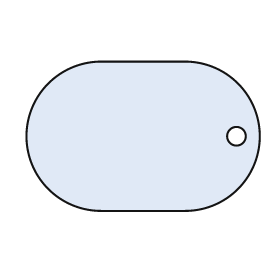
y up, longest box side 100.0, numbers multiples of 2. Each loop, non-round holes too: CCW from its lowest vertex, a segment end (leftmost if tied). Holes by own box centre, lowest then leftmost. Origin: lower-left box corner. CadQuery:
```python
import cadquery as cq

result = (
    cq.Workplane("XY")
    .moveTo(32.0, 0.0)
    .lineTo(68.0, 0.0)
    .threePointArc((100.0, 32.0), (68.0, 64.0))
    .lineTo(32.0, 64.0)
    .threePointArc((0.0, 32.0), (32.0, 0.0))
    .close()
    .moveTo(90.0, 32.0)
    .circle(4.0)
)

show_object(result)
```